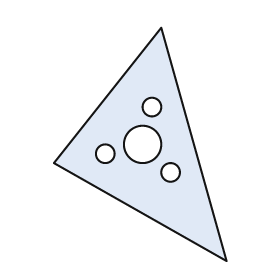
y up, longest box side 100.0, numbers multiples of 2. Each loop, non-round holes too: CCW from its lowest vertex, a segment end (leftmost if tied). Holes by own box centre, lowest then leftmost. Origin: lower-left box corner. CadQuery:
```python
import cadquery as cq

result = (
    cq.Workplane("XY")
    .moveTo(74.0, 0.0)
    .lineTo(46.0, 100.0)
    .lineTo(0.0, 42.0)
    .close()
    .moveTo(50.0, 38.0)
    .circle(4.0)
    .moveTo(22.0, 46.0)
    .circle(4.0)
    .moveTo(38.0, 50.0)
    .circle(8.0)
    .moveTo(42.0, 66.0)
    .circle(4.0)
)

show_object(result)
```